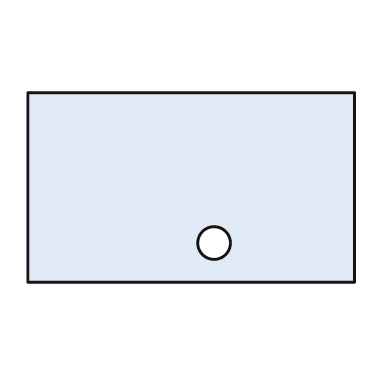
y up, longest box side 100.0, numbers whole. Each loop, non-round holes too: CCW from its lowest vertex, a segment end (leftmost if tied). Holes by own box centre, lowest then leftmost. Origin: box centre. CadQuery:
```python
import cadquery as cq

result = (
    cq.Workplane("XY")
    .moveTo(-50.0, -29.0)
    .lineTo(50.0, -29.0)
    .lineTo(50.0, 29.0)
    .lineTo(-50.0, 29.0)
    .close()
    .moveTo(7.0, -17.0)
    .circle(5.0)
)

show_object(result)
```